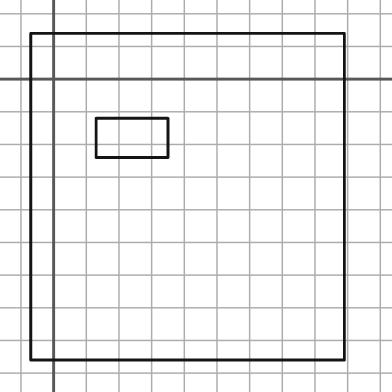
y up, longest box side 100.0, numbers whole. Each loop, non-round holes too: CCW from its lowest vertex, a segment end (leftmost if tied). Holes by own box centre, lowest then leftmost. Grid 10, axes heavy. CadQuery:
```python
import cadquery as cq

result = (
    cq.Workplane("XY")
    .moveTo(-7.0, -86.0)
    .lineTo(89.0, -86.0)
    .lineTo(89.0, 14.0)
    .lineTo(-7.0, 14.0)
    .close()
    .moveTo(13.0, -24.0)
    .lineTo(35.0, -24.0)
    .lineTo(35.0, -12.0)
    .lineTo(13.0, -12.0)
    .close()
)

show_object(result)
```